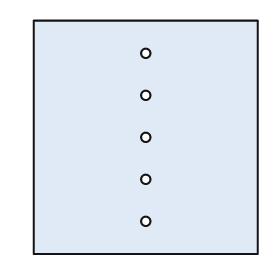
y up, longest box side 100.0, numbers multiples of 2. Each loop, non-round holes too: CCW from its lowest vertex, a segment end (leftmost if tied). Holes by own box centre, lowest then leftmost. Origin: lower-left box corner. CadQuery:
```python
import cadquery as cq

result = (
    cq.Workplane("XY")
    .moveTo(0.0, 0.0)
    .lineTo(96.0, 0.0)
    .lineTo(96.0, 100.0)
    .lineTo(0.0, 100.0)
    .close()
    .moveTo(48.0, 14.0)
    .circle(2.0)
    .moveTo(48.0, 32.0)
    .circle(2.0)
    .moveTo(48.0, 50.0)
    .circle(2.0)
    .moveTo(48.0, 68.0)
    .circle(2.0)
    .moveTo(48.0, 86.0)
    .circle(2.0)
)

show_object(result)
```